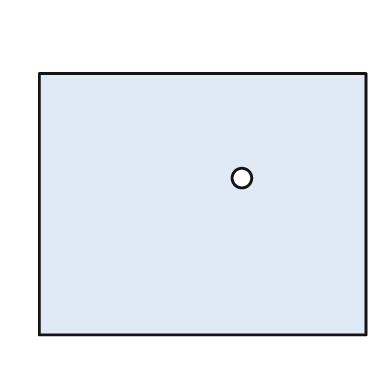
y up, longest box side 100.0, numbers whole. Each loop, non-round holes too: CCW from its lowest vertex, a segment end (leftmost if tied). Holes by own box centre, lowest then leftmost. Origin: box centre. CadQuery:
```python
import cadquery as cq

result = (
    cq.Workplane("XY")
    .moveTo(-50.0, -40.0)
    .lineTo(50.0, -40.0)
    .lineTo(50.0, 40.0)
    .lineTo(-50.0, 40.0)
    .close()
    .moveTo(12.0, 8.0)
    .circle(3.0)
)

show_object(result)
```